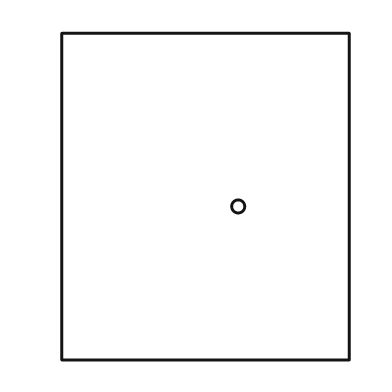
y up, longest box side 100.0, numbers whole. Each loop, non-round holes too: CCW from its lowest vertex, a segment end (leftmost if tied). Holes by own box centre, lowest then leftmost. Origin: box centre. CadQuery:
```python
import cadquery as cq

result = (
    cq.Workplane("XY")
    .moveTo(-44.0, -50.0)
    .lineTo(44.0, -50.0)
    .lineTo(44.0, 50.0)
    .lineTo(-44.0, 50.0)
    .close()
    .moveTo(10.0, -3.0)
    .circle(2.0)
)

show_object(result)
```